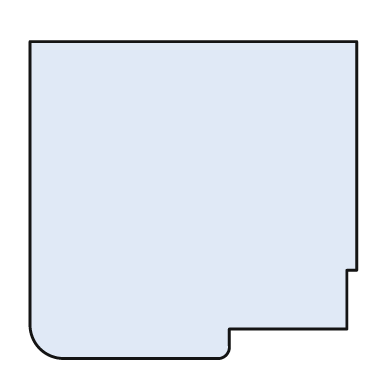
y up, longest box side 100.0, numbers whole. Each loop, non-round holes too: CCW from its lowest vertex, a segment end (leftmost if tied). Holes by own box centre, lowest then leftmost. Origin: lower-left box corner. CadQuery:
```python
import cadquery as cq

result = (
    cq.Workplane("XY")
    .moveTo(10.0, 0.0)
    .lineTo(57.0, 0.0)
    .threePointArc((60.0, 1.0), (61.0, 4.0))
    .lineTo(61.0, 9.0)
    .lineTo(97.0, 9.0)
    .lineTo(97.0, 27.0)
    .lineTo(100.0, 27.0)
    .lineTo(100.0, 97.0)
    .lineTo(0.0, 97.0)
    .lineTo(0.0, 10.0)
    .threePointArc((3.0, 3.0), (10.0, 0.0))
    .close()
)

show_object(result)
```